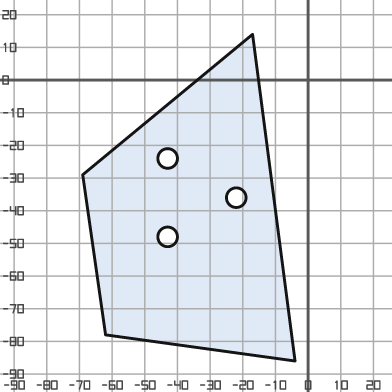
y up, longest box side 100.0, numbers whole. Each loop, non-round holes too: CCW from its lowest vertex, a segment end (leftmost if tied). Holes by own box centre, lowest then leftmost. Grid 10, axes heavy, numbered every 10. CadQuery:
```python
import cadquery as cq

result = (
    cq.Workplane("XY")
    .moveTo(-4.0, -86.0)
    .lineTo(-17.0, 14.0)
    .lineTo(-69.0, -29.0)
    .lineTo(-62.0, -78.0)
    .close()
    .moveTo(-43.0, -48.0)
    .circle(3.0)
    .moveTo(-22.0, -36.0)
    .circle(3.0)
    .moveTo(-43.0, -24.0)
    .circle(3.0)
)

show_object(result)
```